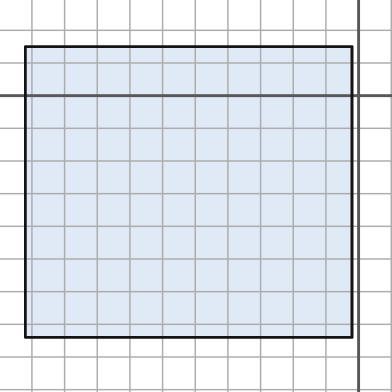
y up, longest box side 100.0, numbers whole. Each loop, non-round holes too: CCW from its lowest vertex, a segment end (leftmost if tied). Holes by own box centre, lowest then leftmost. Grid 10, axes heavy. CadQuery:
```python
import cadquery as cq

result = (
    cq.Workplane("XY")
    .moveTo(-102.0, -74.0)
    .lineTo(-2.0, -74.0)
    .lineTo(-2.0, 15.0)
    .lineTo(-102.0, 15.0)
    .close()
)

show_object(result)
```